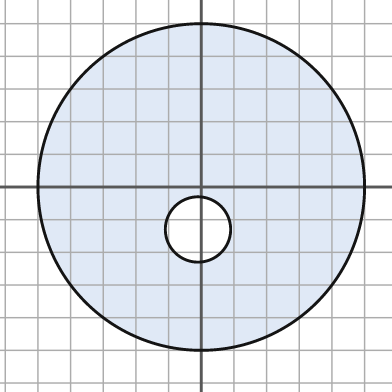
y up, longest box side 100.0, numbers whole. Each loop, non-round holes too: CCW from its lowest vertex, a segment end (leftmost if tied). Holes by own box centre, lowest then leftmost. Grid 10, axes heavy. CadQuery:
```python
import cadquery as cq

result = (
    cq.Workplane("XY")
    .moveTo(0.0, 0.0)
    .circle(50.0)
    .moveTo(-1.0, -13.0)
    .circle(10.0)
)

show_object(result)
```